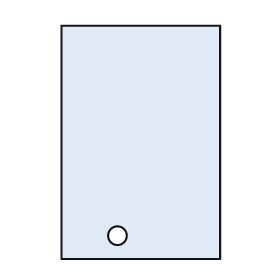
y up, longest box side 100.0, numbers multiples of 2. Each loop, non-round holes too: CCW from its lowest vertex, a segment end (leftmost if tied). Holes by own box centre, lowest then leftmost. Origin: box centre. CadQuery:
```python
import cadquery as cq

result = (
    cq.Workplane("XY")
    .moveTo(-34.0, -50.0)
    .lineTo(34.0, -50.0)
    .lineTo(34.0, 50.0)
    .lineTo(-34.0, 50.0)
    .close()
    .moveTo(-10.0, -40.0)
    .circle(4.0)
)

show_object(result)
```